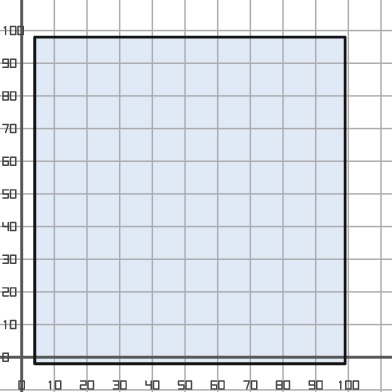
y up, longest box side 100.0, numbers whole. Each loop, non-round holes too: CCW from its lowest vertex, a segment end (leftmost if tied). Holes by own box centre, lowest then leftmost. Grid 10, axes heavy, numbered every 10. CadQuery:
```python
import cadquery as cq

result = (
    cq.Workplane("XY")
    .moveTo(4.0, -2.0)
    .lineTo(99.0, -2.0)
    .lineTo(99.0, 98.0)
    .lineTo(4.0, 98.0)
    .close()
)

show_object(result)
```